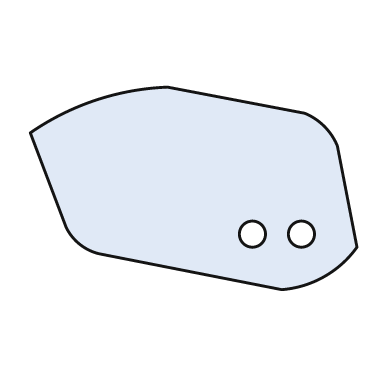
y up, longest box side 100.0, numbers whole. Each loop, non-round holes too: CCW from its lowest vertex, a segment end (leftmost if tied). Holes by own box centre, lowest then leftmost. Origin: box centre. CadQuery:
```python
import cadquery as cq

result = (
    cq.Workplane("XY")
    .moveTo(27.0, -31.0)
    .threePointArc((40.0, -27.0), (50.0, -18.0))
    .lineTo(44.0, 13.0)
    .threePointArc((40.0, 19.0), (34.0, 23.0))
    .lineTo(-8.0, 31.0)
    .threePointArc((-30.0, 27.0), (-50.0, 17.0))
    .lineTo(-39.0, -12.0)
    .threePointArc((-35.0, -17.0), (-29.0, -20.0))
    .close()
    .moveTo(18.0, -14.0)
    .circle(4.0)
    .moveTo(33.0, -14.0)
    .circle(4.0)
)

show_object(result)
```